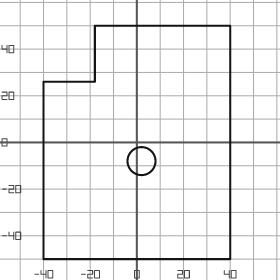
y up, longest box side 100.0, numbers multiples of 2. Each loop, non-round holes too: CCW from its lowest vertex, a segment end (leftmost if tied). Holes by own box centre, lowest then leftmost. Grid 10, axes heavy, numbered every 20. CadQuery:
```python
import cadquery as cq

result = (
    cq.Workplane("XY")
    .moveTo(-40.0, -50.0)
    .lineTo(40.0, -50.0)
    .lineTo(40.0, 50.0)
    .lineTo(-18.0, 50.0)
    .lineTo(-18.0, 26.0)
    .lineTo(-40.0, 26.0)
    .close()
    .moveTo(2.0, -8.0)
    .circle(6.0)
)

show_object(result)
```